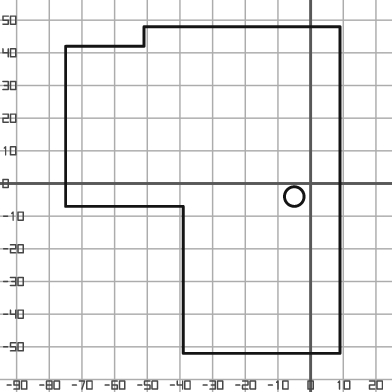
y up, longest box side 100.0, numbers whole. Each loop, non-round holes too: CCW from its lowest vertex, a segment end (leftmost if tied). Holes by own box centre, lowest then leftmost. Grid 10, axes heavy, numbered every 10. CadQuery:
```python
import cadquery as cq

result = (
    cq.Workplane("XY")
    .moveTo(-39.0, -52.0)
    .lineTo(9.0, -52.0)
    .lineTo(9.0, 48.0)
    .lineTo(-51.0, 48.0)
    .lineTo(-51.0, 42.0)
    .lineTo(-75.0, 42.0)
    .lineTo(-75.0, -7.0)
    .lineTo(-39.0, -7.0)
    .close()
    .moveTo(-5.0, -4.0)
    .circle(3.0)
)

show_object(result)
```